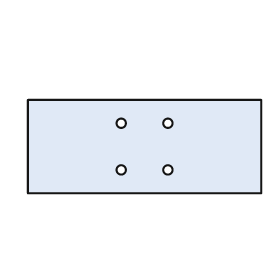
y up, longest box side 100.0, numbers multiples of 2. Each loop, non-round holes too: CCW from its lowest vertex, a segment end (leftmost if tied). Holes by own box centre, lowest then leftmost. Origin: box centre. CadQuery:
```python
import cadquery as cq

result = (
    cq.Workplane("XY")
    .moveTo(-50.0, -20.0)
    .lineTo(50.0, -20.0)
    .lineTo(50.0, 20.0)
    .lineTo(-50.0, 20.0)
    .close()
    .moveTo(-10.0, -10.0)
    .circle(2.0)
    .moveTo(10.0, -10.0)
    .circle(2.0)
    .moveTo(-10.0, 10.0)
    .circle(2.0)
    .moveTo(10.0, 10.0)
    .circle(2.0)
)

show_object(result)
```